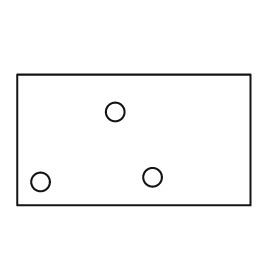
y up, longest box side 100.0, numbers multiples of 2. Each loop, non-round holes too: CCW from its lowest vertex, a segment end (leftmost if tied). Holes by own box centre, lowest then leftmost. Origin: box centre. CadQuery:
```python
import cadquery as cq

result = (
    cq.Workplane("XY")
    .moveTo(-50.0, -28.0)
    .lineTo(50.0, -28.0)
    .lineTo(50.0, 28.0)
    .lineTo(-50.0, 28.0)
    .close()
    .moveTo(-40.0, -18.0)
    .circle(4.0)
    .moveTo(8.0, -16.0)
    .circle(4.0)
    .moveTo(-8.0, 12.0)
    .circle(4.0)
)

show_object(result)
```